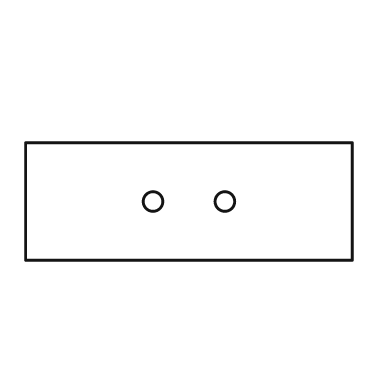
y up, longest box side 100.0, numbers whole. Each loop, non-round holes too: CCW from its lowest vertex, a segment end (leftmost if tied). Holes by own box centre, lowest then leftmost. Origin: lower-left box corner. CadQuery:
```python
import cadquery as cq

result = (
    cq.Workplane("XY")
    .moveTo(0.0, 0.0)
    .lineTo(100.0, 0.0)
    .lineTo(100.0, 36.0)
    .lineTo(0.0, 36.0)
    .close()
    .moveTo(39.0, 18.0)
    .circle(3.0)
    .moveTo(61.0, 18.0)
    .circle(3.0)
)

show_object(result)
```